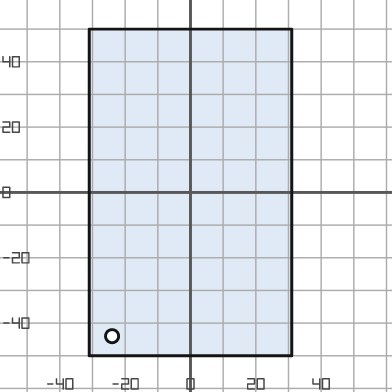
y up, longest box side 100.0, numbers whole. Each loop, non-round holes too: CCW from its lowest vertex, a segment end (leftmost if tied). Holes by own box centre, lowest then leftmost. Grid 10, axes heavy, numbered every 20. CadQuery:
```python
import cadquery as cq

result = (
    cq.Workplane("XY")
    .moveTo(-31.0, -50.0)
    .lineTo(31.0, -50.0)
    .lineTo(31.0, 50.0)
    .lineTo(-31.0, 50.0)
    .close()
    .moveTo(-24.0, -44.0)
    .circle(2.0)
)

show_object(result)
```